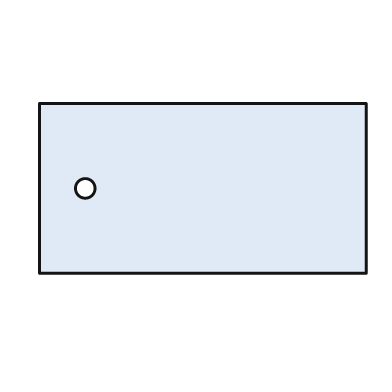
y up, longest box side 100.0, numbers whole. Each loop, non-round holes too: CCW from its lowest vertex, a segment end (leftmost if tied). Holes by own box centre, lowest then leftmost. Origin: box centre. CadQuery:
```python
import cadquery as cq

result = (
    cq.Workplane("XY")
    .moveTo(-50.0, -26.0)
    .lineTo(50.0, -26.0)
    .lineTo(50.0, 26.0)
    .lineTo(-50.0, 26.0)
    .close()
    .moveTo(-36.0, 0.0)
    .circle(3.0)
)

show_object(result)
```